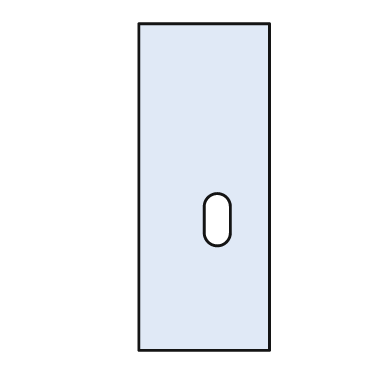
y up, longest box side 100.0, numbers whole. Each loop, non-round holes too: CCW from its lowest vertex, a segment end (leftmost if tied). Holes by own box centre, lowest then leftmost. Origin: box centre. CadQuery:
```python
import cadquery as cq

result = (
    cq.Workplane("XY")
    .moveTo(-20.0, -50.0)
    .lineTo(20.0, -50.0)
    .lineTo(20.0, 50.0)
    .lineTo(-20.0, 50.0)
    .close()
    .moveTo(0.0, -14.0)
    .threePointArc((4.0, -18.0), (8.0, -14.0))
    .lineTo(8.0, -6.0)
    .threePointArc((4.0, -2.0), (0.0, -6.0))
    .close()
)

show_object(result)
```